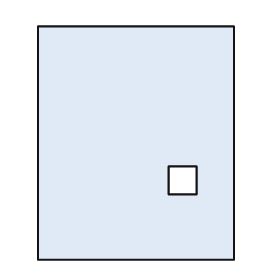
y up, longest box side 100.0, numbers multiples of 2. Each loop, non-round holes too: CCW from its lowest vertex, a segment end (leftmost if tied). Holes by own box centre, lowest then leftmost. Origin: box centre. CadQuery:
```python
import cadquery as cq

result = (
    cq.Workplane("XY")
    .moveTo(-42.0, -50.0)
    .lineTo(42.0, -50.0)
    .lineTo(42.0, 50.0)
    .lineTo(-42.0, 50.0)
    .close()
    .moveTo(14.0, -22.0)
    .lineTo(26.0, -22.0)
    .lineTo(26.0, -10.0)
    .lineTo(14.0, -10.0)
    .close()
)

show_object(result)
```